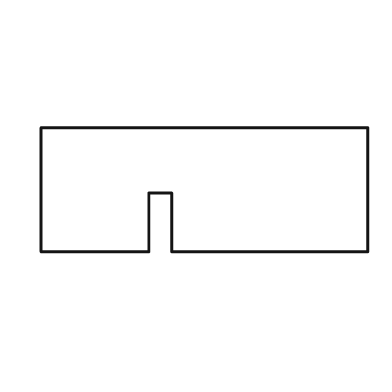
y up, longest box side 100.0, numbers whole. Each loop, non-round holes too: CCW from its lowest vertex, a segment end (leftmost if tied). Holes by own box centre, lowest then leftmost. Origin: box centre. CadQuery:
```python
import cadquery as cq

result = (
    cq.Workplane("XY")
    .moveTo(-50.0, -19.0)
    .lineTo(-17.0, -19.0)
    .lineTo(-17.0, -1.0)
    .lineTo(-10.0, -1.0)
    .lineTo(-10.0, -19.0)
    .lineTo(50.0, -19.0)
    .lineTo(50.0, 19.0)
    .lineTo(-50.0, 19.0)
    .close()
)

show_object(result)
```